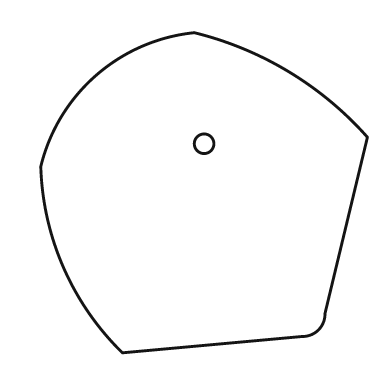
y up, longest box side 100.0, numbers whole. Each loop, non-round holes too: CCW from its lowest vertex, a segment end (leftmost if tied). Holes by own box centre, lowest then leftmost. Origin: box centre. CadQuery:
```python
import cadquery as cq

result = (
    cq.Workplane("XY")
    .moveTo(-25.0, -49.0)
    .lineTo(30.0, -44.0)
    .threePointArc((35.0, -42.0), (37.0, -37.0))
    .lineTo(50.0, 17.0)
    .threePointArc((26.0, 37.0), (-3.0, 49.0))
    .threePointArc((-33.0, 36.0), (-50.0, 8.0))
    .threePointArc((-43.0, -23.0), (-25.0, -49.0))
    .close()
    .moveTo(0.0, 15.0)
    .circle(3.0)
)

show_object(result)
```